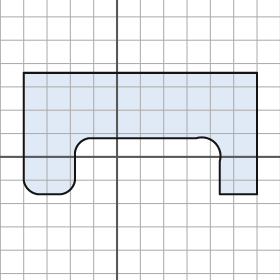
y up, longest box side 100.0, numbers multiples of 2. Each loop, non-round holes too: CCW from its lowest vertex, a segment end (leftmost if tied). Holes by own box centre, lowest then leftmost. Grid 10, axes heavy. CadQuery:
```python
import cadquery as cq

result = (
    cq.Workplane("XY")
    .moveTo(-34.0, -16.0)
    .lineTo(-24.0, -16.0)
    .threePointArc((-20.0, -14.0), (-18.0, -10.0))
    .lineTo(-18.0, 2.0)
    .threePointArc((-16.0, 6.0), (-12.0, 8.0))
    .lineTo(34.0, 8.0)
    .threePointArc((42.0, 6.0), (44.0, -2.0))
    .lineTo(44.0, -16.0)
    .lineTo(60.0, -16.0)
    .lineTo(60.0, 36.0)
    .lineTo(-40.0, 36.0)
    .lineTo(-40.0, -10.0)
    .threePointArc((-38.0, -14.0), (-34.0, -16.0))
    .close()
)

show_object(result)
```